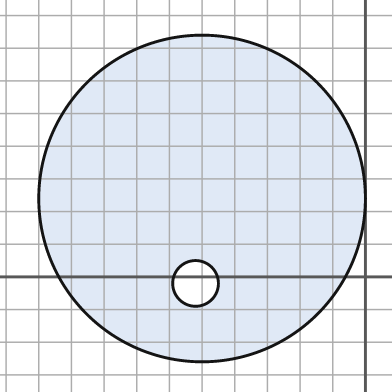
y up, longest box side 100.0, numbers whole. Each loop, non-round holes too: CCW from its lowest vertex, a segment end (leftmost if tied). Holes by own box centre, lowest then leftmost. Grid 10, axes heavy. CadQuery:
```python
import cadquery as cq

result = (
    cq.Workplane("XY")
    .moveTo(-50.0, 24.0)
    .circle(50.0)
    .moveTo(-52.0, -2.0)
    .circle(7.0)
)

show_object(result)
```